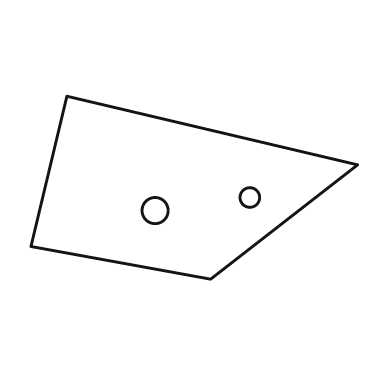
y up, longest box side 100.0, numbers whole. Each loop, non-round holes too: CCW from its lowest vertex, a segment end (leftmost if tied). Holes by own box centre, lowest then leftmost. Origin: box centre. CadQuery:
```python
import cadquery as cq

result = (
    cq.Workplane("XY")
    .moveTo(5.0, -28.0)
    .lineTo(50.0, 7.0)
    .lineTo(-39.0, 28.0)
    .lineTo(-50.0, -18.0)
    .close()
    .moveTo(-12.0, -7.0)
    .circle(4.0)
    .moveTo(17.0, -3.0)
    .circle(3.0)
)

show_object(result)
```